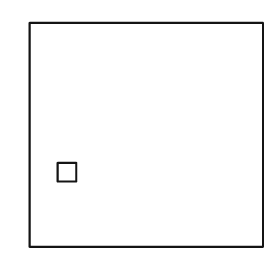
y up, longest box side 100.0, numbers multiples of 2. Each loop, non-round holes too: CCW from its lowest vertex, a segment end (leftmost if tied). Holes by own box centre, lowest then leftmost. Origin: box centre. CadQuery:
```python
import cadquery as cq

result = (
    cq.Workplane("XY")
    .moveTo(-50.0, -48.0)
    .lineTo(50.0, -48.0)
    .lineTo(50.0, 48.0)
    .lineTo(-50.0, 48.0)
    .close()
    .moveTo(-38.0, -20.0)
    .lineTo(-30.0, -20.0)
    .lineTo(-30.0, -12.0)
    .lineTo(-38.0, -12.0)
    .close()
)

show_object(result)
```